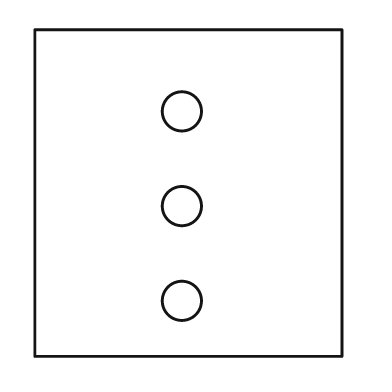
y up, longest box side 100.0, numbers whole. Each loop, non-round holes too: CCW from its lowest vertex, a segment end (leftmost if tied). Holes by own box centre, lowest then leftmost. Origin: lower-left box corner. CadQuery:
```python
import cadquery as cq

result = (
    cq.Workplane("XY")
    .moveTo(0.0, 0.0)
    .lineTo(94.0, 0.0)
    .lineTo(94.0, 100.0)
    .lineTo(0.0, 100.0)
    .close()
    .moveTo(45.0, 17.0)
    .circle(6.0)
    .moveTo(45.0, 46.0)
    .circle(6.0)
    .moveTo(45.0, 75.0)
    .circle(6.0)
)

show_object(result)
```